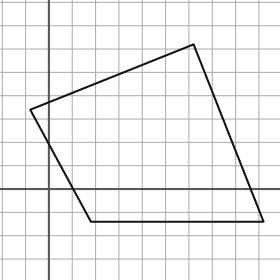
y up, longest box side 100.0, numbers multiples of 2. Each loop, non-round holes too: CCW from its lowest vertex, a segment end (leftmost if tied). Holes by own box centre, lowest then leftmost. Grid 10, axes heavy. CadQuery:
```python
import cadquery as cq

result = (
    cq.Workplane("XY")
    .moveTo(18.0, -14.0)
    .lineTo(92.0, -14.0)
    .lineTo(62.0, 62.0)
    .lineTo(-8.0, 34.0)
    .close()
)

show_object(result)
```